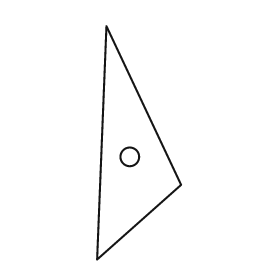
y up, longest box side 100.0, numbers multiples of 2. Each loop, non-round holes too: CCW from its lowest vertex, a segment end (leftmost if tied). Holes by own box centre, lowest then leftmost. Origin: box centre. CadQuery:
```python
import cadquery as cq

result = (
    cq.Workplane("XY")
    .moveTo(-18.0, -50.0)
    .lineTo(18.0, -18.0)
    .lineTo(-14.0, 50.0)
    .close()
    .moveTo(-4.0, -6.0)
    .circle(4.0)
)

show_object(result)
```